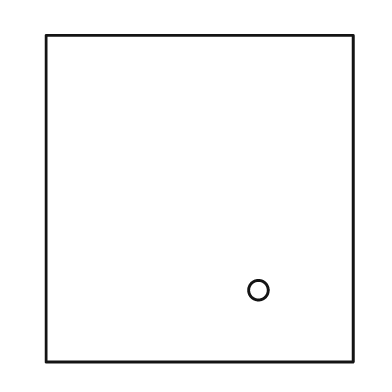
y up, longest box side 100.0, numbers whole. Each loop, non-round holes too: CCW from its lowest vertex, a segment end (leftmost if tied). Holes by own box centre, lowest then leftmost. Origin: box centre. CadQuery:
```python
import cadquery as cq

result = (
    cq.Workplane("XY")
    .moveTo(-47.0, -50.0)
    .lineTo(47.0, -50.0)
    .lineTo(47.0, 50.0)
    .lineTo(-47.0, 50.0)
    .close()
    .moveTo(18.0, -28.0)
    .circle(3.0)
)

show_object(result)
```